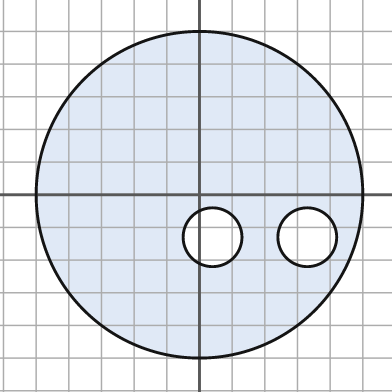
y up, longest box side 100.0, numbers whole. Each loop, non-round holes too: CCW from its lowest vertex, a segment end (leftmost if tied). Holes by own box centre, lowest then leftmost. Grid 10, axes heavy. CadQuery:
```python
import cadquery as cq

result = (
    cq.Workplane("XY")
    .moveTo(0.0, 0.0)
    .circle(50.0)
    .moveTo(4.0, -13.0)
    .circle(9.0)
    .moveTo(33.0, -13.0)
    .circle(9.0)
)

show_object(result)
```